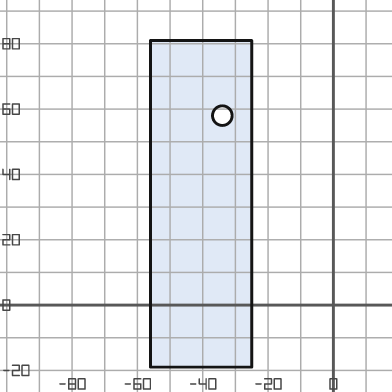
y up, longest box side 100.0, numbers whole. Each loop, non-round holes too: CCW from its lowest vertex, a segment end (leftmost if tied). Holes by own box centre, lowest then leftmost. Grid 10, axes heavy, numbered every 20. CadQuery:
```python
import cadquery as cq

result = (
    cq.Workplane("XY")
    .moveTo(-56.0, -19.0)
    .lineTo(-25.0, -19.0)
    .lineTo(-25.0, 81.0)
    .lineTo(-56.0, 81.0)
    .close()
    .moveTo(-34.0, 58.0)
    .circle(3.0)
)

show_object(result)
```